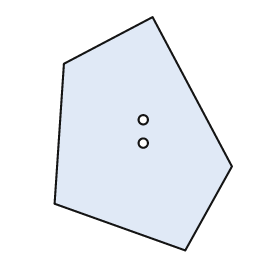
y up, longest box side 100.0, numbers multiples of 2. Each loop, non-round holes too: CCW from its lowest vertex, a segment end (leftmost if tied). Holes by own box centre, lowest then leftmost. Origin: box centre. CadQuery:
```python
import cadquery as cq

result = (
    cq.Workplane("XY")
    .moveTo(18.0, -50.0)
    .lineTo(38.0, -14.0)
    .lineTo(4.0, 50.0)
    .lineTo(-34.0, 30.0)
    .lineTo(-38.0, -30.0)
    .close()
    .moveTo(0.0, -4.0)
    .circle(2.0)
    .moveTo(0.0, 6.0)
    .circle(2.0)
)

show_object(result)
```